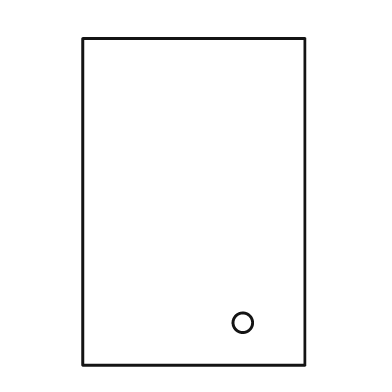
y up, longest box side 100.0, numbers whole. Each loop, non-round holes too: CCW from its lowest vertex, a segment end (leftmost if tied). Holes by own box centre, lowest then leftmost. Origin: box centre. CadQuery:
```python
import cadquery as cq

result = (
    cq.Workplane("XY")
    .moveTo(-34.0, -50.0)
    .lineTo(34.0, -50.0)
    .lineTo(34.0, 50.0)
    .lineTo(-34.0, 50.0)
    .close()
    .moveTo(15.0, -37.0)
    .circle(3.0)
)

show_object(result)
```